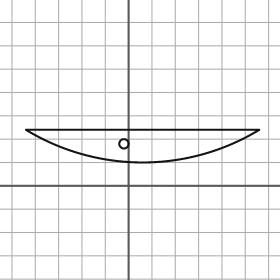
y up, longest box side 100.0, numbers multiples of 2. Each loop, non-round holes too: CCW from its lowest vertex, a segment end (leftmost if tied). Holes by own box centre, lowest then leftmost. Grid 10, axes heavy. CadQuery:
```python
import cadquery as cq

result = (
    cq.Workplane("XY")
    .moveTo(-44.0, 24.0)
    .threePointArc((6.0, 10.0), (56.0, 24.0))
    .close()
    .moveTo(-2.0, 18.0)
    .circle(2.0)
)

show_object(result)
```